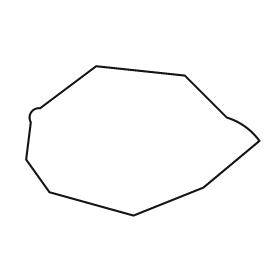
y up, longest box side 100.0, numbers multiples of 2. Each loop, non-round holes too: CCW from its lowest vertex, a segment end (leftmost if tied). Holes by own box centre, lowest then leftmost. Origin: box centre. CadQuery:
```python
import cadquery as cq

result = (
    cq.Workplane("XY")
    .moveTo(-4.0, -32.0)
    .lineTo(26.0, -20.0)
    .lineTo(50.0, 0.0)
    .threePointArc((44.0, 6.0), (36.0, 10.0))
    .lineTo(18.0, 28.0)
    .lineTo(-20.0, 32.0)
    .lineTo(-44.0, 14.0)
    .threePointArc((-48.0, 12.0), (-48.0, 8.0))
    .lineTo(-50.0, -8.0)
    .lineTo(-40.0, -22.0)
    .close()
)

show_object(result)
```